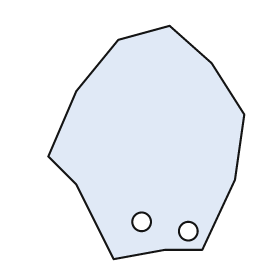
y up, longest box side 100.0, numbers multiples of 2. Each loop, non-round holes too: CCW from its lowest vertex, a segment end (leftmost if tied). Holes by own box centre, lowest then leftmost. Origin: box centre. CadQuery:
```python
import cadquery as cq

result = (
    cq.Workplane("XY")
    .moveTo(-14.0, -50.0)
    .lineTo(8.0, -46.0)
    .lineTo(24.0, -46.0)
    .lineTo(38.0, -16.0)
    .lineTo(42.0, 12.0)
    .lineTo(28.0, 34.0)
    .lineTo(10.0, 50.0)
    .lineTo(-12.0, 44.0)
    .lineTo(-30.0, 22.0)
    .lineTo(-42.0, -6.0)
    .lineTo(-30.0, -18.0)
    .close()
    .moveTo(18.0, -38.0)
    .circle(4.0)
    .moveTo(-2.0, -34.0)
    .circle(4.0)
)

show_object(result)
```